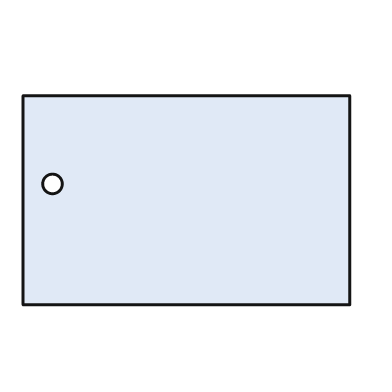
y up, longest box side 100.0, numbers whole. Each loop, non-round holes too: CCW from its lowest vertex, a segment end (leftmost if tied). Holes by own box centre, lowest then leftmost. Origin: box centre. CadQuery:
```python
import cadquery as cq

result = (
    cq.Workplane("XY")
    .moveTo(-50.0, -32.0)
    .lineTo(50.0, -32.0)
    .lineTo(50.0, 32.0)
    .lineTo(-50.0, 32.0)
    .close()
    .moveTo(-41.0, 5.0)
    .circle(3.0)
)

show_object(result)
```